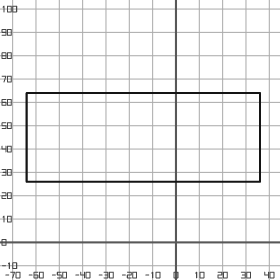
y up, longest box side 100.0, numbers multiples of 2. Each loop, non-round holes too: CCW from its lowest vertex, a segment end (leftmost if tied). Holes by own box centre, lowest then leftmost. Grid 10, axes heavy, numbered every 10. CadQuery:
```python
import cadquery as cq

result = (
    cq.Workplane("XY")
    .moveTo(-64.0, 26.0)
    .lineTo(36.0, 26.0)
    .lineTo(36.0, 64.0)
    .lineTo(-64.0, 64.0)
    .close()
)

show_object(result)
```